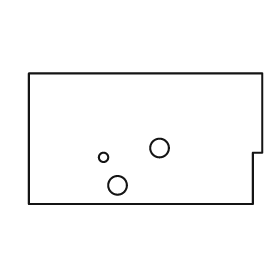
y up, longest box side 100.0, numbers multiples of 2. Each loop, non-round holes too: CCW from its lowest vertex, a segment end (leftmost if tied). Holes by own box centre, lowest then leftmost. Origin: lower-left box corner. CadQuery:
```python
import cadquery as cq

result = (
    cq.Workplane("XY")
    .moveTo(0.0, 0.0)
    .lineTo(96.0, 0.0)
    .lineTo(96.0, 22.0)
    .lineTo(100.0, 22.0)
    .lineTo(100.0, 56.0)
    .lineTo(0.0, 56.0)
    .close()
    .moveTo(38.0, 8.0)
    .circle(4.0)
    .moveTo(32.0, 20.0)
    .circle(2.0)
    .moveTo(56.0, 24.0)
    .circle(4.0)
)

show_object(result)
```